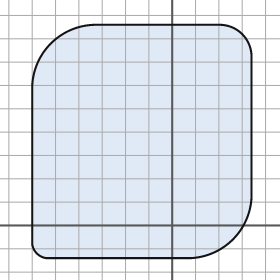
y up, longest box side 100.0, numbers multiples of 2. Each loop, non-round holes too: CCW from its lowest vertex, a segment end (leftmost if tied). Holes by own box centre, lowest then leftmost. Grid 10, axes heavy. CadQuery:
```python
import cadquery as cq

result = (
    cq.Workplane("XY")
    .moveTo(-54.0, -14.0)
    .lineTo(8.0, -14.0)
    .threePointArc((26.0, -6.0), (34.0, 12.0))
    .lineTo(34.0, 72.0)
    .threePointArc((30.0, 82.0), (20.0, 86.0))
    .lineTo(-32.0, 86.0)
    .threePointArc((-52.0, 78.0), (-60.0, 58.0))
    .lineTo(-60.0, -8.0)
    .threePointArc((-58.0, -12.0), (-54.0, -14.0))
    .close()
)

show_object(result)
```